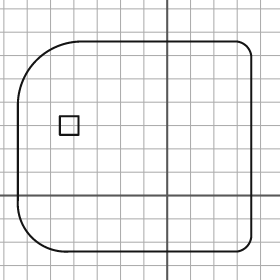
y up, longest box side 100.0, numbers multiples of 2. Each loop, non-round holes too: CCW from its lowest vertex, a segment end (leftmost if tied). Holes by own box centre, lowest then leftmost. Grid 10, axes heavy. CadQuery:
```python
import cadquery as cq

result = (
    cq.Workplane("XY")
    .moveTo(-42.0, -24.0)
    .lineTo(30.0, -24.0)
    .threePointArc((34.0, -22.0), (36.0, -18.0))
    .lineTo(36.0, 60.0)
    .threePointArc((34.0, 64.0), (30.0, 66.0))
    .lineTo(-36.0, 66.0)
    .threePointArc((-56.0, 58.0), (-64.0, 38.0))
    .lineTo(-64.0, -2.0)
    .threePointArc((-58.0, -18.0), (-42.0, -24.0))
    .close()
    .moveTo(-46.0, 26.0)
    .lineTo(-38.0, 26.0)
    .lineTo(-38.0, 34.0)
    .lineTo(-46.0, 34.0)
    .close()
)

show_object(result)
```